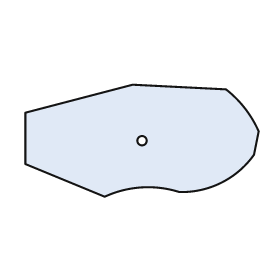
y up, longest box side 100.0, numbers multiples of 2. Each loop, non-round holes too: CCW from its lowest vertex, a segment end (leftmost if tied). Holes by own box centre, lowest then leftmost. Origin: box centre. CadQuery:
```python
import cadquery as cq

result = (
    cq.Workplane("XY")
    .moveTo(-16.0, -24.0)
    .threePointArc((0.0, -20.0), (16.0, -22.0))
    .threePointArc((34.0, -18.0), (48.0, -6.0))
    .lineTo(50.0, 4.0)
    .threePointArc((44.0, 14.0), (36.0, 22.0))
    .lineTo(-4.0, 24.0)
    .lineTo(-50.0, 12.0)
    .lineTo(-50.0, -10.0)
    .close()
    .moveTo(0.0, 0.0)
    .circle(2.0)
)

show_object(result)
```